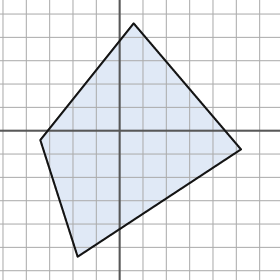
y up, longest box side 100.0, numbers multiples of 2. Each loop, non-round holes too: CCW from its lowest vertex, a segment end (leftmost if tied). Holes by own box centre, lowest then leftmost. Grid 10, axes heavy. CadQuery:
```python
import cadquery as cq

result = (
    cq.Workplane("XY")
    .moveTo(-18.0, -54.0)
    .lineTo(52.0, -8.0)
    .lineTo(6.0, 46.0)
    .lineTo(-34.0, -4.0)
    .close()
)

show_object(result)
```